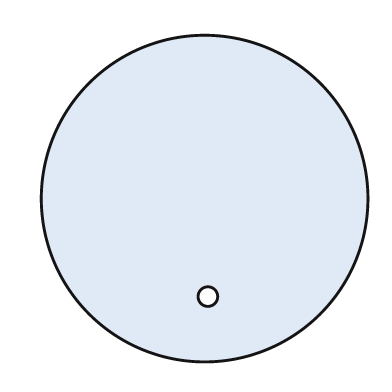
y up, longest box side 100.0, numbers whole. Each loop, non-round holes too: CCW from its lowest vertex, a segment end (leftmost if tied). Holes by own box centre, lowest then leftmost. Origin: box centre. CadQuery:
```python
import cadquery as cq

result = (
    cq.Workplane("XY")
    .moveTo(0.0, 0.0)
    .circle(50.0)
    .moveTo(1.0, -30.0)
    .circle(3.0)
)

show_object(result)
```